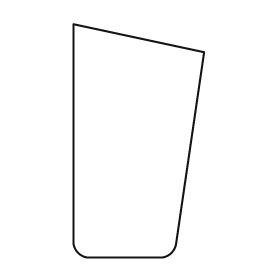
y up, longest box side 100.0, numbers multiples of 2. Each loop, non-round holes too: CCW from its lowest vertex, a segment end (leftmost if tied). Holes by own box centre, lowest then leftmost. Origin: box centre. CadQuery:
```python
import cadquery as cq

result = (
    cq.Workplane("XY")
    .moveTo(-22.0, -50.0)
    .lineTo(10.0, -50.0)
    .threePointArc((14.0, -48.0), (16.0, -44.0))
    .lineTo(28.0, 38.0)
    .lineTo(-28.0, 50.0)
    .lineTo(-28.0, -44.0)
    .threePointArc((-26.0, -48.0), (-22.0, -50.0))
    .close()
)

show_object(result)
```